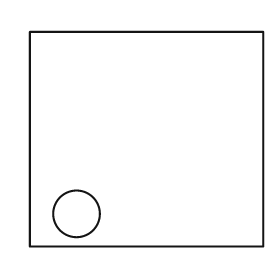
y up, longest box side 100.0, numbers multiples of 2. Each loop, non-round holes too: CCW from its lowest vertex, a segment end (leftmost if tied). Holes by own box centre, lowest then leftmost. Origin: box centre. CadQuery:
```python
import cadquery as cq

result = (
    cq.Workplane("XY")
    .moveTo(-50.0, -46.0)
    .lineTo(50.0, -46.0)
    .lineTo(50.0, 46.0)
    .lineTo(-50.0, 46.0)
    .close()
    .moveTo(-30.0, -32.0)
    .circle(10.0)
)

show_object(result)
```